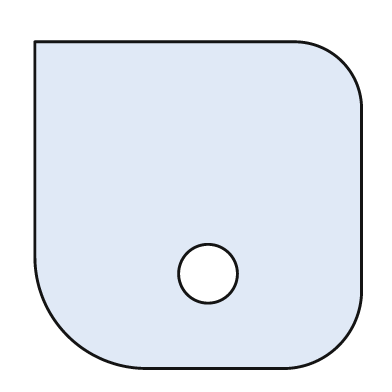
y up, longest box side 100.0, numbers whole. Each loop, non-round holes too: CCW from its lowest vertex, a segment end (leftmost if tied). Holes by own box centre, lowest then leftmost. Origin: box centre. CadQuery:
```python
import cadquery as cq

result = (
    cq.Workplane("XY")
    .moveTo(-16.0, -50.0)
    .lineTo(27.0, -50.0)
    .threePointArc((43.0, -43.0), (50.0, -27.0))
    .lineTo(50.0, 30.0)
    .threePointArc((44.0, 44.0), (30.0, 50.0))
    .lineTo(-50.0, 50.0)
    .lineTo(-50.0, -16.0)
    .threePointArc((-40.0, -40.0), (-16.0, -50.0))
    .close()
    .moveTo(3.0, -21.0)
    .circle(9.0)
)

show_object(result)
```